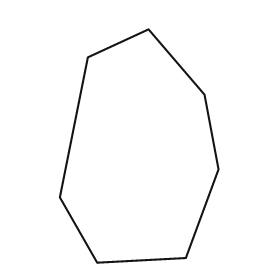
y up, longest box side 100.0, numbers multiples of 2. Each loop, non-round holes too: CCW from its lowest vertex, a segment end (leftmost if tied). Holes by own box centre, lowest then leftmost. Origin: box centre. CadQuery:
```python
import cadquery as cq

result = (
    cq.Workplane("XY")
    .moveTo(-18.0, -50.0)
    .lineTo(20.0, -48.0)
    .lineTo(34.0, -10.0)
    .lineTo(28.0, 22.0)
    .lineTo(4.0, 50.0)
    .lineTo(-22.0, 38.0)
    .lineTo(-34.0, -22.0)
    .close()
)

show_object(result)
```